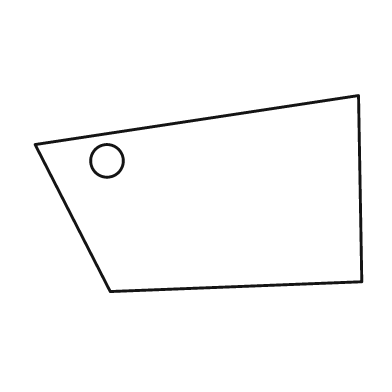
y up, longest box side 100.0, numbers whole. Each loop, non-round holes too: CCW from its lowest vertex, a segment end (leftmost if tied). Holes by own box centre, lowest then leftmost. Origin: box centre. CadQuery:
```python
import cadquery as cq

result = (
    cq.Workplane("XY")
    .moveTo(-27.0, -30.0)
    .lineTo(50.0, -27.0)
    .lineTo(49.0, 30.0)
    .lineTo(-50.0, 15.0)
    .close()
    .moveTo(-28.0, 10.0)
    .circle(5.0)
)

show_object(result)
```